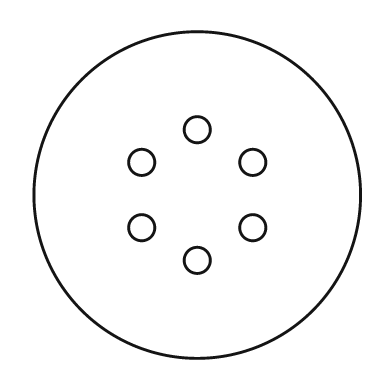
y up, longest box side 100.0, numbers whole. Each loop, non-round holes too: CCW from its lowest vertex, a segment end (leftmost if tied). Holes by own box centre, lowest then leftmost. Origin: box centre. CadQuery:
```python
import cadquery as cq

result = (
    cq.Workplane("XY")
    .moveTo(0.0, 0.0)
    .circle(50.0)
    .moveTo(0.0, -20.0)
    .circle(4.0)
    .moveTo(-17.0, -10.0)
    .circle(4.0)
    .moveTo(17.0, -10.0)
    .circle(4.0)
    .moveTo(-17.0, 10.0)
    .circle(4.0)
    .moveTo(17.0, 10.0)
    .circle(4.0)
    .moveTo(0.0, 20.0)
    .circle(4.0)
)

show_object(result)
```